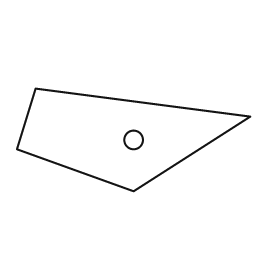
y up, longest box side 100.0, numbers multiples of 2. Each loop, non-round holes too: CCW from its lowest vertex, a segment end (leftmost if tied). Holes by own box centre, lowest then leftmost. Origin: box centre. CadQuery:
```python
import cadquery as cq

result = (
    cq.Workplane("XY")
    .moveTo(0.0, -22.0)
    .lineTo(50.0, 10.0)
    .lineTo(-42.0, 22.0)
    .lineTo(-50.0, -4.0)
    .close()
    .moveTo(0.0, 0.0)
    .circle(4.0)
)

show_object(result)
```